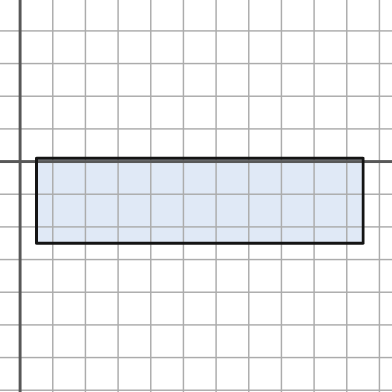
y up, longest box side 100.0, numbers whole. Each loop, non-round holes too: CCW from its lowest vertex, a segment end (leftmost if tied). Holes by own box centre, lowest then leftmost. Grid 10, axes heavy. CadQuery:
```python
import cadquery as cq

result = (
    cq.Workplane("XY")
    .moveTo(5.0, -25.0)
    .lineTo(105.0, -25.0)
    .lineTo(105.0, 1.0)
    .lineTo(5.0, 1.0)
    .close()
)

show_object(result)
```